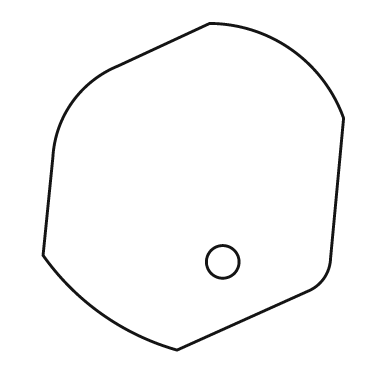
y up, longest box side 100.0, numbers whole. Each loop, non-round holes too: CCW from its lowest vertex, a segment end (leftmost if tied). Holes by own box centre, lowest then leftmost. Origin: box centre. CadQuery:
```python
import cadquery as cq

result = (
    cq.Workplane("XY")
    .moveTo(-5.0, -50.0)
    .lineTo(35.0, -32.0)
    .threePointArc((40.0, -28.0), (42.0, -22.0))
    .lineTo(46.0, 21.0)
    .threePointArc((30.0, 42.0), (5.0, 50.0))
    .lineTo(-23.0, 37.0)
    .threePointArc((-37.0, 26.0), (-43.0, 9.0))
    .lineTo(-46.0, -21.0)
    .threePointArc((-28.0, -39.0), (-5.0, -50.0))
    .close()
    .moveTo(9.0, -23.0)
    .circle(5.0)
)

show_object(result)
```